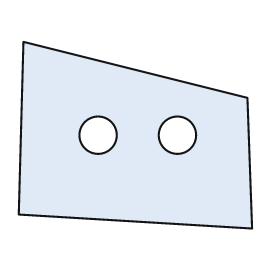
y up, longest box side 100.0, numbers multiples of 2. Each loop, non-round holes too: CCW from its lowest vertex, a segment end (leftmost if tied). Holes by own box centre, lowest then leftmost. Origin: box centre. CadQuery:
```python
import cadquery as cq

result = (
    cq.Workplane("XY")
    .moveTo(50.0, -40.0)
    .lineTo(48.0, 16.0)
    .lineTo(-48.0, 40.0)
    .lineTo(-50.0, -34.0)
    .close()
    .moveTo(-16.0, 0.0)
    .circle(8.0)
    .moveTo(18.0, 0.0)
    .circle(8.0)
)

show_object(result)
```